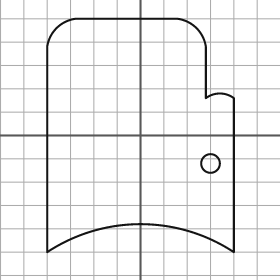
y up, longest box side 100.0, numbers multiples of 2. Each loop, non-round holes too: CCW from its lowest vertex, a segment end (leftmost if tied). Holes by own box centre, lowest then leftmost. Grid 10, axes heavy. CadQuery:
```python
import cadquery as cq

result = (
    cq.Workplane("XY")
    .moveTo(-40.0, -50.0)
    .threePointArc((0.0, -38.0), (40.0, -50.0))
    .lineTo(40.0, 16.0)
    .threePointArc((34.0, 18.0), (28.0, 16.0))
    .lineTo(28.0, 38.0)
    .threePointArc((24.0, 46.0), (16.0, 50.0))
    .lineTo(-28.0, 50.0)
    .threePointArc((-36.0, 46.0), (-40.0, 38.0))
    .close()
    .moveTo(30.0, -12.0)
    .circle(4.0)
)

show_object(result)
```